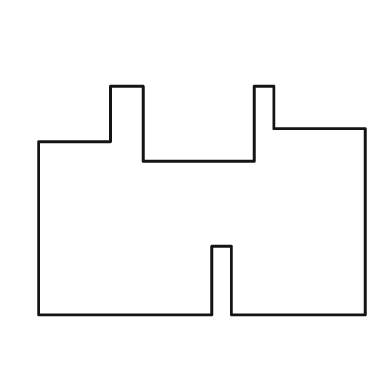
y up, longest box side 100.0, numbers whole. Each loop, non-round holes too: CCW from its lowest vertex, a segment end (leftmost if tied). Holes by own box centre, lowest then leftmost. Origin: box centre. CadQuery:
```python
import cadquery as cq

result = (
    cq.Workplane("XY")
    .moveTo(-50.0, -35.0)
    .lineTo(3.0, -35.0)
    .lineTo(3.0, -14.0)
    .lineTo(9.0, -14.0)
    .lineTo(9.0, -35.0)
    .lineTo(50.0, -35.0)
    .lineTo(50.0, 22.0)
    .lineTo(22.0, 22.0)
    .lineTo(22.0, 35.0)
    .lineTo(16.0, 35.0)
    .lineTo(16.0, 12.0)
    .lineTo(-18.0, 12.0)
    .lineTo(-18.0, 35.0)
    .lineTo(-28.0, 35.0)
    .lineTo(-28.0, 18.0)
    .lineTo(-50.0, 18.0)
    .close()
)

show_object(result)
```